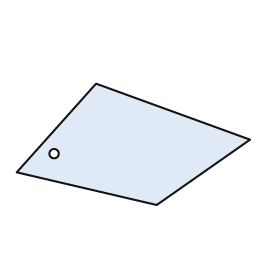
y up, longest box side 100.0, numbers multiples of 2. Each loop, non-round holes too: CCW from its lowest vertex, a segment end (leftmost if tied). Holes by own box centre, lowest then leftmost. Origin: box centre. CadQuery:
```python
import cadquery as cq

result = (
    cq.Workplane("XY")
    .moveTo(10.0, -26.0)
    .lineTo(50.0, 2.0)
    .lineTo(-16.0, 26.0)
    .lineTo(-50.0, -12.0)
    .close()
    .moveTo(-34.0, -4.0)
    .circle(2.0)
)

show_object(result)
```